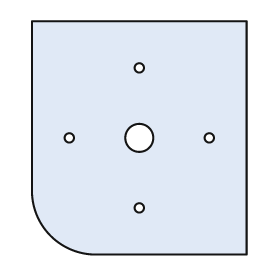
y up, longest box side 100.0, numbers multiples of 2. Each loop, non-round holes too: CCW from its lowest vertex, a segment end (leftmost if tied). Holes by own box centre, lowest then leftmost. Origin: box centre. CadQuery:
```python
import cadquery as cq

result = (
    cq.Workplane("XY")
    .moveTo(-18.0, -50.0)
    .lineTo(46.0, -50.0)
    .lineTo(46.0, 50.0)
    .lineTo(-46.0, 50.0)
    .lineTo(-46.0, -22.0)
    .threePointArc((-38.0, -42.0), (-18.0, -50.0))
    .close()
    .moveTo(0.0, -30.0)
    .circle(2.0)
    .moveTo(-30.0, 0.0)
    .circle(2.0)
    .moveTo(0.0, 0.0)
    .circle(6.0)
    .moveTo(30.0, 0.0)
    .circle(2.0)
    .moveTo(0.0, 30.0)
    .circle(2.0)
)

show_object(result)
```